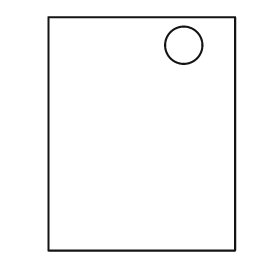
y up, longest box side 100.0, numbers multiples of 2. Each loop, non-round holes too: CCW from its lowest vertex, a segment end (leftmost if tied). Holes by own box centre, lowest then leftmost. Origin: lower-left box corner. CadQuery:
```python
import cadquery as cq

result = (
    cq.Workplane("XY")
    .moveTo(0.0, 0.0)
    .lineTo(80.0, 0.0)
    .lineTo(80.0, 100.0)
    .lineTo(0.0, 100.0)
    .close()
    .moveTo(58.0, 88.0)
    .circle(8.0)
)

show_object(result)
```